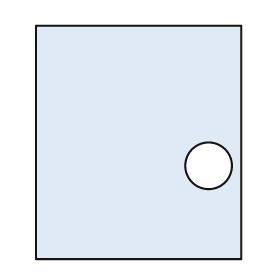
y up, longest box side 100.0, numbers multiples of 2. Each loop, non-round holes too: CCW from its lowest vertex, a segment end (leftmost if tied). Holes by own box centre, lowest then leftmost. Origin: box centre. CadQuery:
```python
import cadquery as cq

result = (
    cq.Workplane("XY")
    .moveTo(-44.0, -50.0)
    .lineTo(44.0, -50.0)
    .lineTo(44.0, 50.0)
    .lineTo(-44.0, 50.0)
    .close()
    .moveTo(30.0, -10.0)
    .circle(10.0)
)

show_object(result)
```